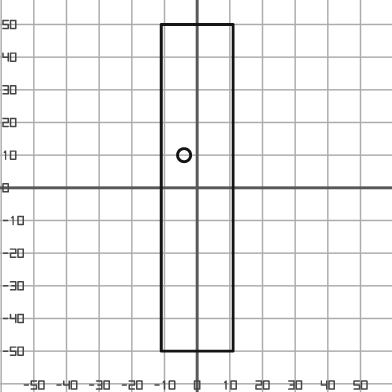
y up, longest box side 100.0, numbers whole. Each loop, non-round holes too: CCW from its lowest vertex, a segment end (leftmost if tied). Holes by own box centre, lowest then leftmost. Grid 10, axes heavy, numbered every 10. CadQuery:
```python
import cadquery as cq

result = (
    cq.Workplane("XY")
    .moveTo(-11.0, -50.0)
    .lineTo(11.0, -50.0)
    .lineTo(11.0, 50.0)
    .lineTo(-11.0, 50.0)
    .close()
    .moveTo(-4.0, 10.0)
    .circle(2.0)
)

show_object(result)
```